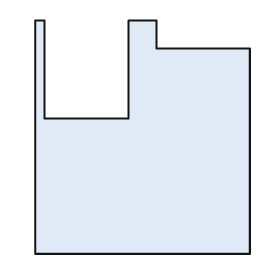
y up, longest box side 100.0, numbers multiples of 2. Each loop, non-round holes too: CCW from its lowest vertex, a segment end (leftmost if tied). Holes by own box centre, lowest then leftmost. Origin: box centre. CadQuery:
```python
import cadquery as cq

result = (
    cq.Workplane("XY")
    .moveTo(-46.0, -50.0)
    .lineTo(46.0, -50.0)
    .lineTo(46.0, 38.0)
    .lineTo(6.0, 38.0)
    .lineTo(6.0, 50.0)
    .lineTo(-6.0, 50.0)
    .lineTo(-6.0, 8.0)
    .lineTo(-42.0, 8.0)
    .lineTo(-42.0, 50.0)
    .lineTo(-46.0, 50.0)
    .close()
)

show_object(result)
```